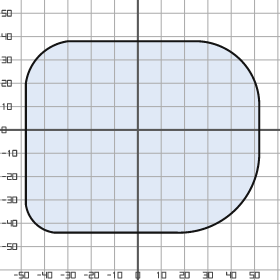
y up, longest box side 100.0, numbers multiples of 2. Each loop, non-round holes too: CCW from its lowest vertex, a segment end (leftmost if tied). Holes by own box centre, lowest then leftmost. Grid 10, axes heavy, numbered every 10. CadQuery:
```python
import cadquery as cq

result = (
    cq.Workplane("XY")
    .moveTo(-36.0, -44.0)
    .lineTo(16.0, -44.0)
    .threePointArc((42.0, -34.0), (52.0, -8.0))
    .lineTo(52.0, 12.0)
    .threePointArc((44.0, 30.0), (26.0, 38.0))
    .lineTo(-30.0, 38.0)
    .threePointArc((-42.0, 32.0), (-48.0, 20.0))
    .lineTo(-48.0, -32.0)
    .threePointArc((-44.0, -40.0), (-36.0, -44.0))
    .close()
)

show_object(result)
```